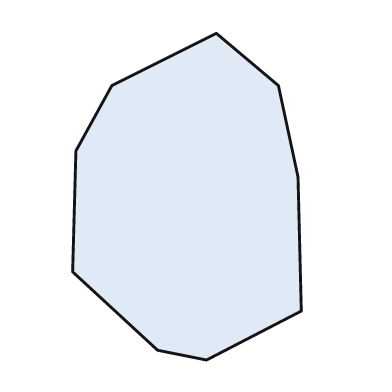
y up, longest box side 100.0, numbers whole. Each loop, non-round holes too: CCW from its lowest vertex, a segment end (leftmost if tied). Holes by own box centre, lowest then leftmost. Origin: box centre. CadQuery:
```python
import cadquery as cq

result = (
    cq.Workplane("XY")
    .moveTo(6.0, -50.0)
    .lineTo(35.0, -35.0)
    .lineTo(34.0, 6.0)
    .lineTo(28.0, 34.0)
    .lineTo(9.0, 50.0)
    .lineTo(-23.0, 34.0)
    .lineTo(-34.0, 14.0)
    .lineTo(-35.0, -23.0)
    .lineTo(-9.0, -47.0)
    .close()
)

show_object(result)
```